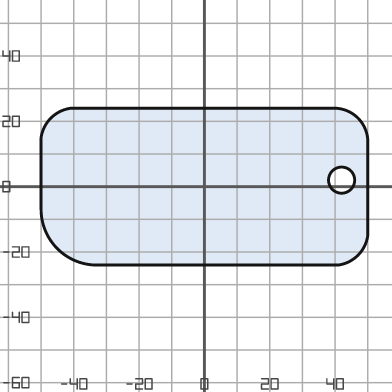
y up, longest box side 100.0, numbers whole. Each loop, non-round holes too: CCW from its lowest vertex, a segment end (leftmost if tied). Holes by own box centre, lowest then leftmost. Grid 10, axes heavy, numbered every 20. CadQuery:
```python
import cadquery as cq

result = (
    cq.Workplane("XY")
    .moveTo(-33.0, -24.0)
    .lineTo(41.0, -24.0)
    .threePointArc((47.0, -21.0), (50.0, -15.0))
    .lineTo(50.0, 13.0)
    .threePointArc((47.0, 21.0), (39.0, 24.0))
    .lineTo(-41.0, 24.0)
    .threePointArc((-47.0, 21.0), (-50.0, 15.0))
    .lineTo(-50.0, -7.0)
    .threePointArc((-45.0, -19.0), (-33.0, -24.0))
    .close()
    .moveTo(42.0, 2.0)
    .circle(4.0)
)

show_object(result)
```